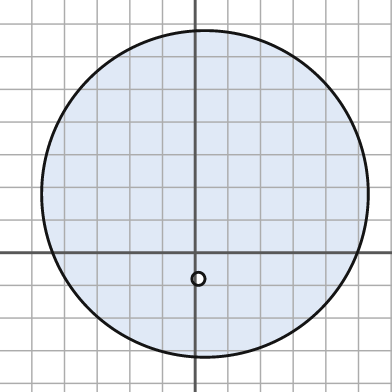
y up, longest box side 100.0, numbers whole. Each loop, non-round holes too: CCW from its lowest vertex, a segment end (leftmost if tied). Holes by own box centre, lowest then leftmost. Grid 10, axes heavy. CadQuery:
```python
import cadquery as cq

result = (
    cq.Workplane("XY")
    .moveTo(3.0, 18.0)
    .circle(50.0)
    .moveTo(1.0, -8.0)
    .circle(2.0)
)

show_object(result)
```